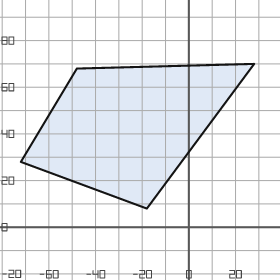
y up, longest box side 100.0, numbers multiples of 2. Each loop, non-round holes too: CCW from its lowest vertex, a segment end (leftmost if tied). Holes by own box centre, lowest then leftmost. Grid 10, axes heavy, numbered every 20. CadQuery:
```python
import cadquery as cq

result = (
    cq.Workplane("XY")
    .moveTo(-18.0, 8.0)
    .lineTo(28.0, 70.0)
    .lineTo(-48.0, 68.0)
    .lineTo(-72.0, 28.0)
    .close()
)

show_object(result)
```